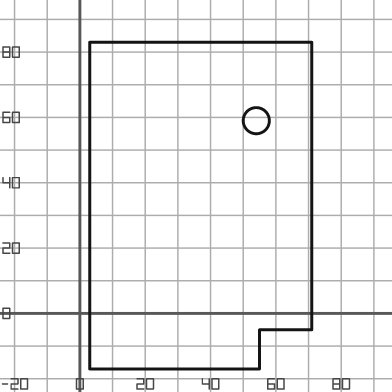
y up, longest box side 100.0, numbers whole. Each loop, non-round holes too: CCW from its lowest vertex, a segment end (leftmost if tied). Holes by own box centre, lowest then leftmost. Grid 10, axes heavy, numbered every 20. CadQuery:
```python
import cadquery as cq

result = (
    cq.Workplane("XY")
    .moveTo(3.0, -17.0)
    .lineTo(55.0, -17.0)
    .lineTo(55.0, -5.0)
    .lineTo(71.0, -5.0)
    .lineTo(71.0, 83.0)
    .lineTo(3.0, 83.0)
    .close()
    .moveTo(54.0, 59.0)
    .circle(4.0)
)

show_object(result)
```